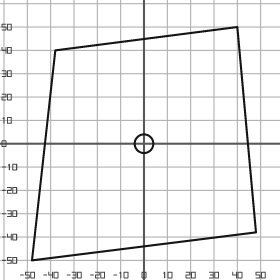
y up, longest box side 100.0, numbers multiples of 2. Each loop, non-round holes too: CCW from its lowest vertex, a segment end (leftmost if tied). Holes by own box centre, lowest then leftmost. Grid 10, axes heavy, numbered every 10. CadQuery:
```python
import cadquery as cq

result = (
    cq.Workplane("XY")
    .moveTo(-48.0, -50.0)
    .lineTo(48.0, -38.0)
    .lineTo(40.0, 50.0)
    .lineTo(-38.0, 40.0)
    .close()
    .moveTo(0.0, 0.0)
    .circle(4.0)
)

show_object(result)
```